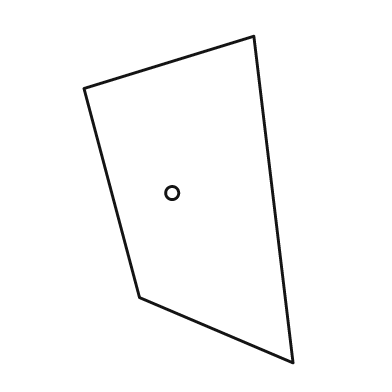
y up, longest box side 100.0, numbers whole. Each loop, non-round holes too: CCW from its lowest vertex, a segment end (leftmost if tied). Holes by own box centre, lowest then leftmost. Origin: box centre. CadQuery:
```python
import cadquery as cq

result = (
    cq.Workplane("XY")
    .moveTo(32.0, -50.0)
    .lineTo(20.0, 50.0)
    .lineTo(-32.0, 34.0)
    .lineTo(-15.0, -30.0)
    .close()
    .moveTo(-5.0, 2.0)
    .circle(2.0)
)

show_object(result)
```